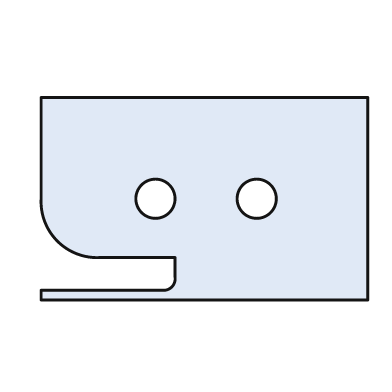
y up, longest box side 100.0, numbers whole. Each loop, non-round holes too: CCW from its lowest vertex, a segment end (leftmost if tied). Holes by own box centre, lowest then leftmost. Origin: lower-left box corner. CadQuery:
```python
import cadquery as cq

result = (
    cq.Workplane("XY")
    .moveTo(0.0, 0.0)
    .lineTo(100.0, 0.0)
    .lineTo(100.0, 62.0)
    .lineTo(0.0, 62.0)
    .lineTo(0.0, 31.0)
    .threePointArc((5.0, 18.0), (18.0, 13.0))
    .lineTo(41.0, 13.0)
    .lineTo(41.0, 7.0)
    .threePointArc((40.0, 4.0), (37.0, 3.0))
    .lineTo(0.0, 3.0)
    .close()
    .moveTo(35.0, 31.0)
    .circle(6.0)
    .moveTo(66.0, 31.0)
    .circle(6.0)
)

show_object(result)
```